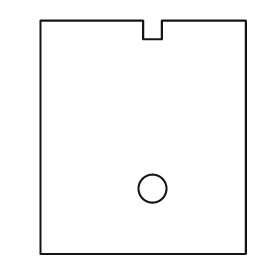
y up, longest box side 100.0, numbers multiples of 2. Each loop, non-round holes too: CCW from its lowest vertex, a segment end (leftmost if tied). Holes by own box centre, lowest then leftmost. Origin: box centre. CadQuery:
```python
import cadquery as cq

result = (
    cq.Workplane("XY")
    .moveTo(-44.0, -50.0)
    .lineTo(44.0, -50.0)
    .lineTo(44.0, 50.0)
    .lineTo(8.0, 50.0)
    .lineTo(8.0, 42.0)
    .lineTo(0.0, 42.0)
    .lineTo(0.0, 50.0)
    .lineTo(-44.0, 50.0)
    .close()
    .moveTo(4.0, -22.0)
    .circle(6.0)
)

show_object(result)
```